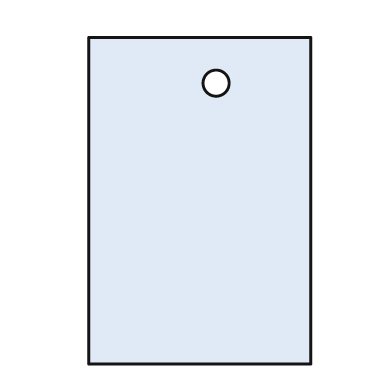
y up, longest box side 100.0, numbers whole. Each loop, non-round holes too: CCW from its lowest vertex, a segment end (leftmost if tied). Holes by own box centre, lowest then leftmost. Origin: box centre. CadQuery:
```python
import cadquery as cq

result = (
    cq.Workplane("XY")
    .moveTo(-34.0, -50.0)
    .lineTo(34.0, -50.0)
    .lineTo(34.0, 50.0)
    .lineTo(-34.0, 50.0)
    .close()
    .moveTo(5.0, 36.0)
    .circle(4.0)
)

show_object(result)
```